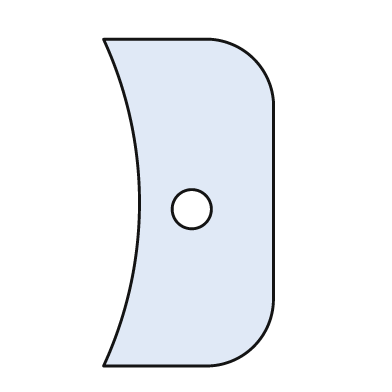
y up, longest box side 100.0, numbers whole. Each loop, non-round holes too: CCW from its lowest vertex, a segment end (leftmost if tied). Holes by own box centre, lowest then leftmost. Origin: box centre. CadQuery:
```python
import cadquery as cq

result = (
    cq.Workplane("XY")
    .moveTo(-26.0, -50.0)
    .lineTo(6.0, -50.0)
    .threePointArc((20.0, -44.0), (26.0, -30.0))
    .lineTo(26.0, 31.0)
    .threePointArc((20.0, 44.0), (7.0, 50.0))
    .lineTo(-26.0, 50.0)
    .threePointArc((-15.0, 0.0), (-26.0, -50.0))
    .close()
    .moveTo(1.0, -2.0)
    .circle(6.0)
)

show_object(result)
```